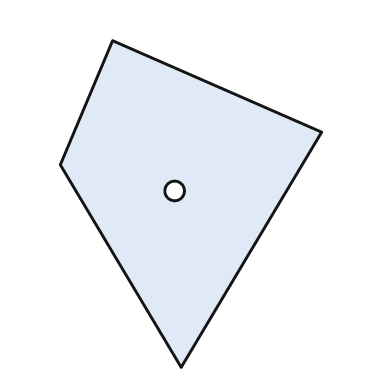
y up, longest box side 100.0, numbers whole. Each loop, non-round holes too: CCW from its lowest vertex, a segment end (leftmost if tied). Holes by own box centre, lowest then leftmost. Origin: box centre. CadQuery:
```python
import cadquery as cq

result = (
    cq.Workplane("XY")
    .moveTo(-3.0, -50.0)
    .lineTo(40.0, 22.0)
    .lineTo(-24.0, 50.0)
    .lineTo(-40.0, 12.0)
    .close()
    .moveTo(-5.0, 4.0)
    .circle(3.0)
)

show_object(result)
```